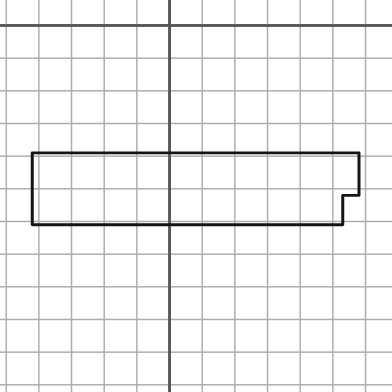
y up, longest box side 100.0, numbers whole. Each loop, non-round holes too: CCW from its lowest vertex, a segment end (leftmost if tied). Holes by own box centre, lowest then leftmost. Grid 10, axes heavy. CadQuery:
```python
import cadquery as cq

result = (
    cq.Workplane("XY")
    .moveTo(-42.0, -61.0)
    .lineTo(53.0, -61.0)
    .lineTo(53.0, -52.0)
    .lineTo(58.0, -52.0)
    .lineTo(58.0, -39.0)
    .lineTo(-42.0, -39.0)
    .close()
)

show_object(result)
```